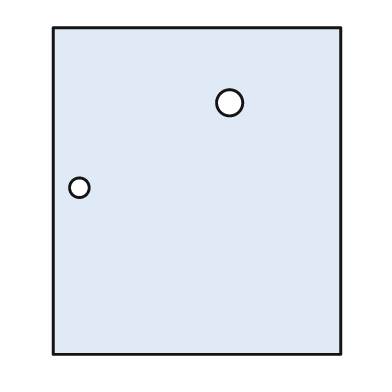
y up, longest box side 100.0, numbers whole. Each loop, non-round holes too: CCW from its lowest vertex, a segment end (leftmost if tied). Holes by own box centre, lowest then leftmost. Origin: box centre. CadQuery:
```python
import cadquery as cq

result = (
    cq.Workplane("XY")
    .moveTo(-44.0, -50.0)
    .lineTo(44.0, -50.0)
    .lineTo(44.0, 50.0)
    .lineTo(-44.0, 50.0)
    .close()
    .moveTo(-36.0, 1.0)
    .circle(3.0)
    .moveTo(10.0, 27.0)
    .circle(4.0)
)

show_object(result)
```